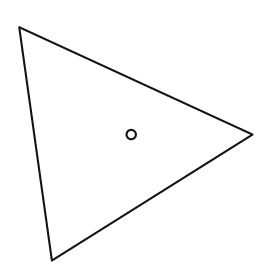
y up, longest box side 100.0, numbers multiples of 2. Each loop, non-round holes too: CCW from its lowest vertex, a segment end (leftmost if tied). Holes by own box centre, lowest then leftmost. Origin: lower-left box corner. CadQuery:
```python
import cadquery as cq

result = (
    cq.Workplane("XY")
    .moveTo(14.0, 0.0)
    .lineTo(100.0, 54.0)
    .lineTo(0.0, 100.0)
    .close()
    .moveTo(48.0, 54.0)
    .circle(2.0)
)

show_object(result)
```